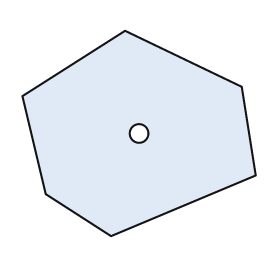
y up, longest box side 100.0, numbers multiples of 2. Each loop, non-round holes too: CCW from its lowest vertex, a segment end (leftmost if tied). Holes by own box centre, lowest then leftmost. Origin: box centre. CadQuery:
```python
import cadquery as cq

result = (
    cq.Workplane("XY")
    .moveTo(-12.0, -44.0)
    .lineTo(50.0, -18.0)
    .lineTo(44.0, 20.0)
    .lineTo(-6.0, 44.0)
    .lineTo(-50.0, 16.0)
    .lineTo(-40.0, -26.0)
    .close()
    .moveTo(0.0, 0.0)
    .circle(4.0)
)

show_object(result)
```